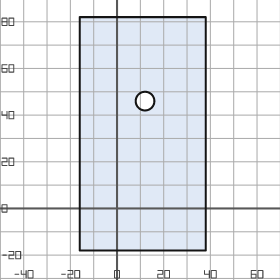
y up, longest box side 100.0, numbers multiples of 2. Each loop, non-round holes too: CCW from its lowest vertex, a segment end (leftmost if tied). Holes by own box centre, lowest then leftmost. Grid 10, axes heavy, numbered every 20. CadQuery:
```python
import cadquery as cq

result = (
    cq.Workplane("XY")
    .moveTo(-16.0, -18.0)
    .lineTo(38.0, -18.0)
    .lineTo(38.0, 82.0)
    .lineTo(-16.0, 82.0)
    .close()
    .moveTo(12.0, 46.0)
    .circle(4.0)
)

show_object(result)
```